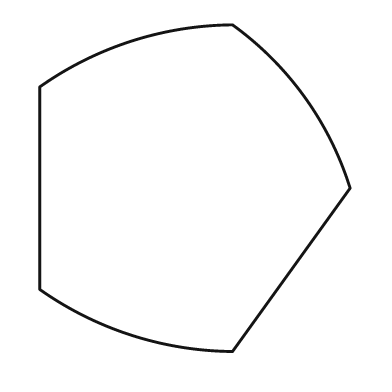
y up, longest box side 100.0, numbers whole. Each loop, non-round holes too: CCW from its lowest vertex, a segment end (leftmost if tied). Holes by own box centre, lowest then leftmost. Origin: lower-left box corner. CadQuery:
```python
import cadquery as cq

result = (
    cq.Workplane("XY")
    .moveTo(59.0, 0.0)
    .lineTo(95.0, 50.0)
    .threePointArc((81.0, 78.0), (59.0, 100.0))
    .threePointArc((28.0, 95.0), (0.0, 81.0))
    .lineTo(0.0, 19.0)
    .threePointArc((28.0, 5.0), (59.0, 0.0))
    .close()
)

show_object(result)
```